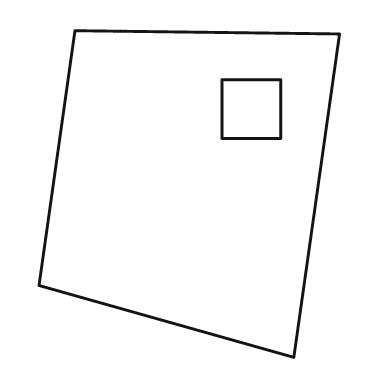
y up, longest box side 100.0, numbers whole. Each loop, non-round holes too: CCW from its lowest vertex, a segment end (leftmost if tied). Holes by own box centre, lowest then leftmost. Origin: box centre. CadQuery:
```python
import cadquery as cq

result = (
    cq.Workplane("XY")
    .moveTo(32.0, -50.0)
    .lineTo(46.0, 49.0)
    .lineTo(-35.0, 50.0)
    .lineTo(-46.0, -28.0)
    .close()
    .moveTo(10.0, 17.0)
    .lineTo(28.0, 17.0)
    .lineTo(28.0, 35.0)
    .lineTo(10.0, 35.0)
    .close()
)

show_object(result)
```